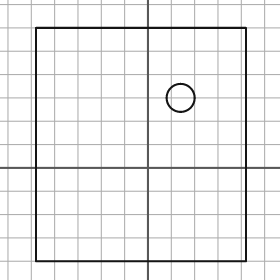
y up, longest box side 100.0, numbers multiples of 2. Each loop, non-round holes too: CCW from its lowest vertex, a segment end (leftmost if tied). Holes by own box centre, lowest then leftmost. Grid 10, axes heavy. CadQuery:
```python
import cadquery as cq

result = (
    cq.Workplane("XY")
    .moveTo(-48.0, -40.0)
    .lineTo(42.0, -40.0)
    .lineTo(42.0, 60.0)
    .lineTo(-48.0, 60.0)
    .close()
    .moveTo(14.0, 30.0)
    .circle(6.0)
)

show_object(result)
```